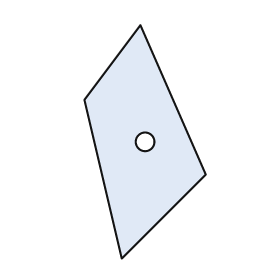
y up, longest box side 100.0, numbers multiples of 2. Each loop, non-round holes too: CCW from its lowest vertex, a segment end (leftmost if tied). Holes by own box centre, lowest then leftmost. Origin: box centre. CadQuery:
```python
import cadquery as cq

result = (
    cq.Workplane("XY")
    .moveTo(-10.0, -50.0)
    .lineTo(26.0, -14.0)
    .lineTo(-2.0, 50.0)
    .lineTo(-26.0, 18.0)
    .close()
    .moveTo(0.0, 0.0)
    .circle(4.0)
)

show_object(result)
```